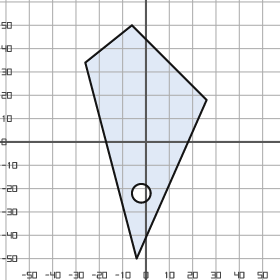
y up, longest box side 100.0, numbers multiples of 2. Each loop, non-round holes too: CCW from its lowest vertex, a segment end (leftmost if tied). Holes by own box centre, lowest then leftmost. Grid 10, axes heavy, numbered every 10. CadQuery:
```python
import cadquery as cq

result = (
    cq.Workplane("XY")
    .moveTo(-4.0, -50.0)
    .lineTo(26.0, 18.0)
    .lineTo(-6.0, 50.0)
    .lineTo(-26.0, 34.0)
    .close()
    .moveTo(-2.0, -22.0)
    .circle(4.0)
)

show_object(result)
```